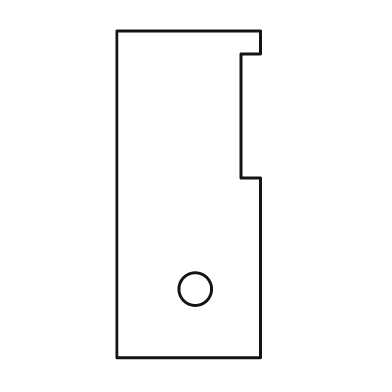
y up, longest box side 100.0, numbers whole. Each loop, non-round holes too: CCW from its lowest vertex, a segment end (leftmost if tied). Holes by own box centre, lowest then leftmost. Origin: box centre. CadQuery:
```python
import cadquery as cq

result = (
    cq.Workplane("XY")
    .moveTo(-22.0, -50.0)
    .lineTo(22.0, -50.0)
    .lineTo(22.0, 5.0)
    .lineTo(16.0, 5.0)
    .lineTo(16.0, 43.0)
    .lineTo(22.0, 43.0)
    .lineTo(22.0, 50.0)
    .lineTo(-22.0, 50.0)
    .close()
    .moveTo(2.0, -29.0)
    .circle(5.0)
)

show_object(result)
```